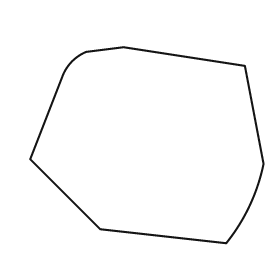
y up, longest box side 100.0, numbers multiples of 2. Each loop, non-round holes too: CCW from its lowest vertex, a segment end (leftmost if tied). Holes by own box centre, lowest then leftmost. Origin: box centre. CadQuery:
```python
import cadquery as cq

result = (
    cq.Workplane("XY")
    .moveTo(34.0, -42.0)
    .threePointArc((44.0, -26.0), (50.0, -8.0))
    .lineTo(42.0, 34.0)
    .lineTo(-10.0, 42.0)
    .lineTo(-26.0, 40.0)
    .threePointArc((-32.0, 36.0), (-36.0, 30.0))
    .lineTo(-50.0, -6.0)
    .lineTo(-20.0, -36.0)
    .close()
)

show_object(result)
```